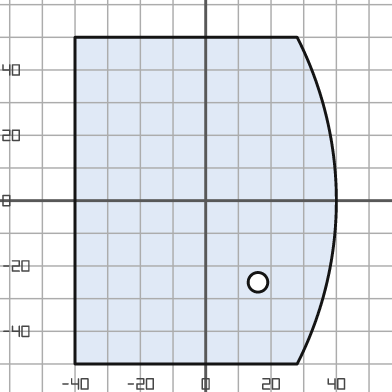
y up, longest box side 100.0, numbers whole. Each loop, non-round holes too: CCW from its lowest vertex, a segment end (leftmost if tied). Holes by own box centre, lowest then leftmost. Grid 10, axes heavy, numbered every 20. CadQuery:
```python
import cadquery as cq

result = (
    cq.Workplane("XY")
    .moveTo(-40.0, -50.0)
    .lineTo(28.0, -50.0)
    .threePointArc((40.0, 0.0), (28.0, 50.0))
    .lineTo(-40.0, 50.0)
    .close()
    .moveTo(16.0, -25.0)
    .circle(3.0)
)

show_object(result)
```